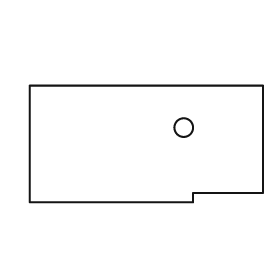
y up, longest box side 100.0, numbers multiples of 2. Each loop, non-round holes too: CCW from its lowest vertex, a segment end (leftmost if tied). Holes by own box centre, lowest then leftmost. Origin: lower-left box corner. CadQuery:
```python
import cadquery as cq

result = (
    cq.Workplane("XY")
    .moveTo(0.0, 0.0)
    .lineTo(70.0, 0.0)
    .lineTo(70.0, 4.0)
    .lineTo(100.0, 4.0)
    .lineTo(100.0, 50.0)
    .lineTo(0.0, 50.0)
    .close()
    .moveTo(66.0, 32.0)
    .circle(4.0)
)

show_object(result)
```